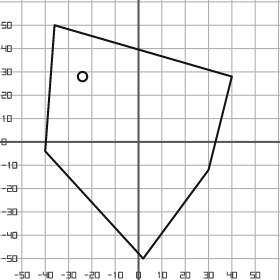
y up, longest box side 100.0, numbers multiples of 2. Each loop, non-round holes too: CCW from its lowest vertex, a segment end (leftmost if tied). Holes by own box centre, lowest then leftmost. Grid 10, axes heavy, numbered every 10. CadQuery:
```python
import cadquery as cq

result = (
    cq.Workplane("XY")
    .moveTo(2.0, -50.0)
    .lineTo(30.0, -12.0)
    .lineTo(40.0, 28.0)
    .lineTo(-36.0, 50.0)
    .lineTo(-40.0, -4.0)
    .close()
    .moveTo(-24.0, 28.0)
    .circle(2.0)
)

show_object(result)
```